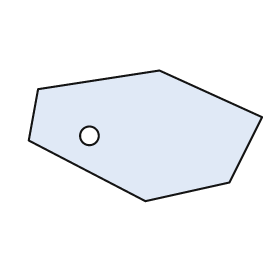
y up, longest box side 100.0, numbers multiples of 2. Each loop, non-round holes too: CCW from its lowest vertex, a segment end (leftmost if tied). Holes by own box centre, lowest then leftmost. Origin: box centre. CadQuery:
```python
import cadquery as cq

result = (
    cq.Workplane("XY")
    .moveTo(0.0, -28.0)
    .lineTo(36.0, -20.0)
    .lineTo(50.0, 8.0)
    .lineTo(6.0, 28.0)
    .lineTo(-46.0, 20.0)
    .lineTo(-50.0, -2.0)
    .close()
    .moveTo(-24.0, 0.0)
    .circle(4.0)
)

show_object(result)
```